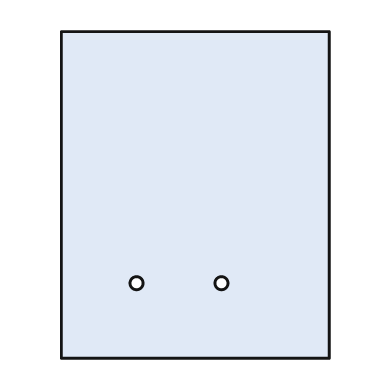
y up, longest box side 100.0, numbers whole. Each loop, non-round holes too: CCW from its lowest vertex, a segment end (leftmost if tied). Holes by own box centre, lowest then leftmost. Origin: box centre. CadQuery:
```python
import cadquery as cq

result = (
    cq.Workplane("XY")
    .moveTo(-41.0, -50.0)
    .lineTo(41.0, -50.0)
    .lineTo(41.0, 50.0)
    .lineTo(-41.0, 50.0)
    .close()
    .moveTo(-18.0, -27.0)
    .circle(2.0)
    .moveTo(8.0, -27.0)
    .circle(2.0)
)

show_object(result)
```